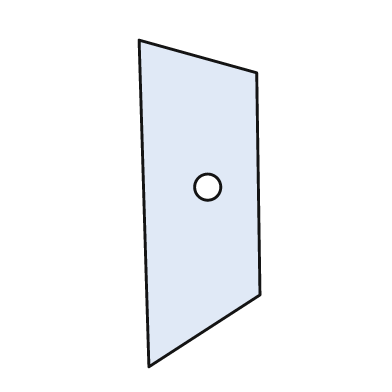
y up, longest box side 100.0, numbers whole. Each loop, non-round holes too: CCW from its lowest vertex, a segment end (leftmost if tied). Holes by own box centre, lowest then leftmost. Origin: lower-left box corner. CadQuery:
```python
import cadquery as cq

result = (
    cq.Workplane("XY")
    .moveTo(3.0, 0.0)
    .lineTo(37.0, 22.0)
    .lineTo(36.0, 90.0)
    .lineTo(0.0, 100.0)
    .close()
    .moveTo(21.0, 55.0)
    .circle(4.0)
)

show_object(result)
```